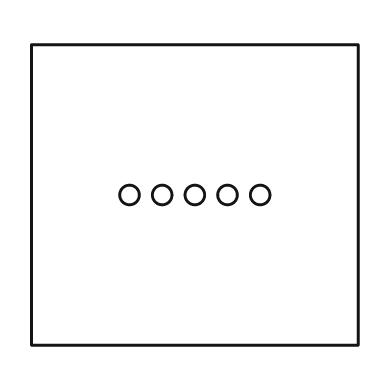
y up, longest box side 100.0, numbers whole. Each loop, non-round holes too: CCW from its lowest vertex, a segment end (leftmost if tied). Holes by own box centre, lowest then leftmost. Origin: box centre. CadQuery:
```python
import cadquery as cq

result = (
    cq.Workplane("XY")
    .moveTo(-50.0, -46.0)
    .lineTo(50.0, -46.0)
    .lineTo(50.0, 46.0)
    .lineTo(-50.0, 46.0)
    .close()
    .moveTo(-20.0, 0.0)
    .circle(3.0)
    .moveTo(-10.0, 0.0)
    .circle(3.0)
    .moveTo(0.0, 0.0)
    .circle(3.0)
    .moveTo(10.0, 0.0)
    .circle(3.0)
    .moveTo(20.0, 0.0)
    .circle(3.0)
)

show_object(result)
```